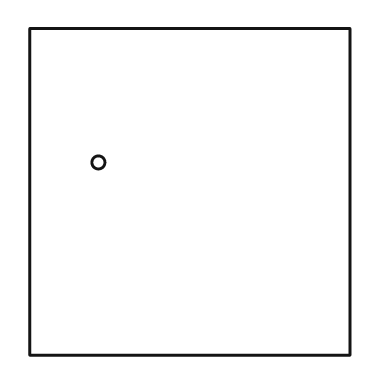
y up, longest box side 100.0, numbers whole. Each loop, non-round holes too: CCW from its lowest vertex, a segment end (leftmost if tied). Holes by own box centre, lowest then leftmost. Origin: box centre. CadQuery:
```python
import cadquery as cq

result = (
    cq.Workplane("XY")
    .moveTo(-49.0, -50.0)
    .lineTo(49.0, -50.0)
    .lineTo(49.0, 50.0)
    .lineTo(-49.0, 50.0)
    .close()
    .moveTo(-28.0, 9.0)
    .circle(2.0)
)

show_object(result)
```